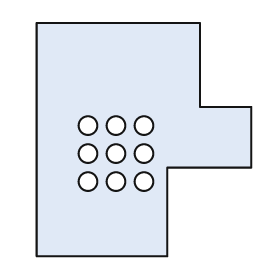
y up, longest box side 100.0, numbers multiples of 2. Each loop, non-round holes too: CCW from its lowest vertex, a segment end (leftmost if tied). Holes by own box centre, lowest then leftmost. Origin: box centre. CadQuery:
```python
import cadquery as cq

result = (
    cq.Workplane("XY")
    .moveTo(-46.0, -50.0)
    .lineTo(10.0, -50.0)
    .lineTo(10.0, -12.0)
    .lineTo(46.0, -12.0)
    .lineTo(46.0, 14.0)
    .lineTo(24.0, 14.0)
    .lineTo(24.0, 50.0)
    .lineTo(-46.0, 50.0)
    .close()
    .moveTo(-24.0, -18.0)
    .circle(4.0)
    .moveTo(-12.0, -18.0)
    .circle(4.0)
    .moveTo(0.0, -18.0)
    .circle(4.0)
    .moveTo(-24.0, -6.0)
    .circle(4.0)
    .moveTo(-12.0, -6.0)
    .circle(4.0)
    .moveTo(0.0, -6.0)
    .circle(4.0)
    .moveTo(-24.0, 6.0)
    .circle(4.0)
    .moveTo(-12.0, 6.0)
    .circle(4.0)
    .moveTo(0.0, 6.0)
    .circle(4.0)
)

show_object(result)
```